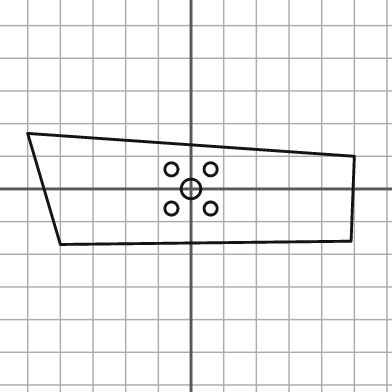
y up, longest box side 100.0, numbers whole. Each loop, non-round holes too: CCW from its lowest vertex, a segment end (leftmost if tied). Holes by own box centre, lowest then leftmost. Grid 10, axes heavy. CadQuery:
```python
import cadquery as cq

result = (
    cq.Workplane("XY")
    .moveTo(-40.0, -17.0)
    .lineTo(49.0, -16.0)
    .lineTo(50.0, 10.0)
    .lineTo(-50.0, 17.0)
    .close()
    .moveTo(-6.0, -6.0)
    .circle(2.0)
    .moveTo(6.0, -6.0)
    .circle(2.0)
    .moveTo(0.0, 0.0)
    .circle(3.0)
    .moveTo(-6.0, 6.0)
    .circle(2.0)
    .moveTo(6.0, 6.0)
    .circle(2.0)
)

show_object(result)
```